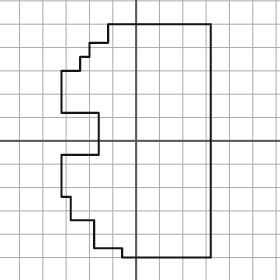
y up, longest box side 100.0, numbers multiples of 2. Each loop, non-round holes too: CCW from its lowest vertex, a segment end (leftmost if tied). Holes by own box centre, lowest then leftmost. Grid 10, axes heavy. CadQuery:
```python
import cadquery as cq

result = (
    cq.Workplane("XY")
    .moveTo(-6.0, -50.0)
    .lineTo(32.0, -50.0)
    .lineTo(32.0, 50.0)
    .lineTo(-12.0, 50.0)
    .lineTo(-12.0, 42.0)
    .lineTo(-20.0, 42.0)
    .lineTo(-20.0, 36.0)
    .lineTo(-24.0, 36.0)
    .lineTo(-24.0, 30.0)
    .lineTo(-32.0, 30.0)
    .lineTo(-32.0, 12.0)
    .lineTo(-16.0, 12.0)
    .lineTo(-16.0, -6.0)
    .lineTo(-32.0, -6.0)
    .lineTo(-32.0, -24.0)
    .lineTo(-28.0, -24.0)
    .lineTo(-28.0, -34.0)
    .lineTo(-18.0, -34.0)
    .lineTo(-18.0, -46.0)
    .lineTo(-6.0, -46.0)
    .close()
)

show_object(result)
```